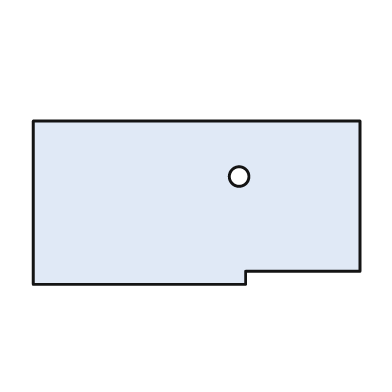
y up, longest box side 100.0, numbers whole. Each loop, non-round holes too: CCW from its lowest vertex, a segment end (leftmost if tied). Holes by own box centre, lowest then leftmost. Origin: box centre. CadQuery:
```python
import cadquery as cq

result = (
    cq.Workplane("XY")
    .moveTo(-50.0, -25.0)
    .lineTo(15.0, -25.0)
    .lineTo(15.0, -21.0)
    .lineTo(50.0, -21.0)
    .lineTo(50.0, 25.0)
    .lineTo(-50.0, 25.0)
    .close()
    .moveTo(13.0, 8.0)
    .circle(3.0)
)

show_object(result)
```